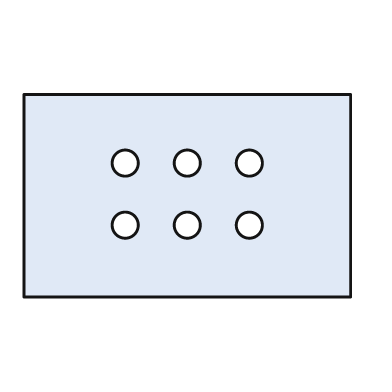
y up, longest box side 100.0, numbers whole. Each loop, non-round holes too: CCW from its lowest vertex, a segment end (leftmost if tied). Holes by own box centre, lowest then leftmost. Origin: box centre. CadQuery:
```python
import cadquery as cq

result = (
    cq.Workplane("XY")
    .moveTo(-50.0, -31.0)
    .lineTo(50.0, -31.0)
    .lineTo(50.0, 31.0)
    .lineTo(-50.0, 31.0)
    .close()
    .moveTo(-19.0, -9.0)
    .circle(4.0)
    .moveTo(0.0, -9.0)
    .circle(4.0)
    .moveTo(19.0, -9.0)
    .circle(4.0)
    .moveTo(-19.0, 10.0)
    .circle(4.0)
    .moveTo(0.0, 10.0)
    .circle(4.0)
    .moveTo(19.0, 10.0)
    .circle(4.0)
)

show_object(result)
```